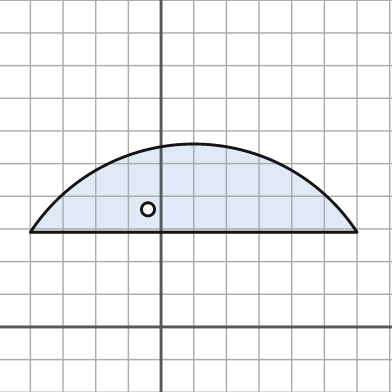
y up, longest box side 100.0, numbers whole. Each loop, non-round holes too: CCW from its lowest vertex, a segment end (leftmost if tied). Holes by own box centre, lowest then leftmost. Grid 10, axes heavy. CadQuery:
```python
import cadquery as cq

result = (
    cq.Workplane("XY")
    .moveTo(-40.0, 29.0)
    .lineTo(60.0, 29.0)
    .threePointArc((10.0, 56.0), (-40.0, 29.0))
    .close()
    .moveTo(-4.0, 36.0)
    .circle(2.0)
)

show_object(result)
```